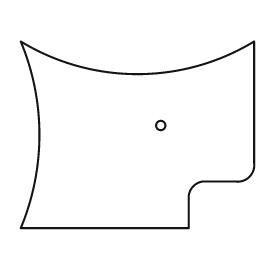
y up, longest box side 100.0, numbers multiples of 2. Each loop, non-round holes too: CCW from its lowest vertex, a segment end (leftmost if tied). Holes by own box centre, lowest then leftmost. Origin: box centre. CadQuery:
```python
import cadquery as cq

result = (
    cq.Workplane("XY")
    .moveTo(-50.0, -40.0)
    .lineTo(22.0, -40.0)
    .lineTo(22.0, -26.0)
    .threePointArc((24.0, -22.0), (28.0, -20.0))
    .lineTo(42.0, -20.0)
    .threePointArc((48.0, -18.0), (50.0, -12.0))
    .lineTo(50.0, 40.0)
    .threePointArc((0.0, 26.0), (-50.0, 40.0))
    .threePointArc((-42.0, 0.0), (-50.0, -40.0))
    .close()
    .moveTo(10.0, 4.0)
    .circle(2.0)
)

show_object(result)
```